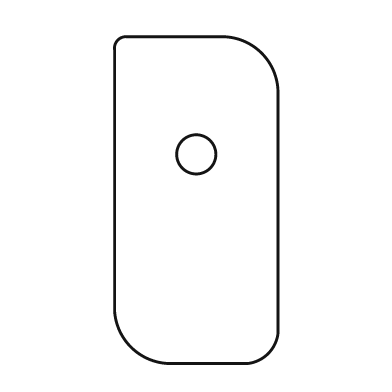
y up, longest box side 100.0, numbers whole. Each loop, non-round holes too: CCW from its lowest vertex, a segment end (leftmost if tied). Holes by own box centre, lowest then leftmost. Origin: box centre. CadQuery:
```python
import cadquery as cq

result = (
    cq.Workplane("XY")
    .moveTo(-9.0, -50.0)
    .lineTo(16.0, -50.0)
    .threePointArc((22.0, -47.0), (25.0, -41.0))
    .lineTo(25.0, 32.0)
    .threePointArc((20.0, 45.0), (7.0, 50.0))
    .lineTo(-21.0, 50.0)
    .threePointArc((-24.0, 49.0), (-25.0, 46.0))
    .lineTo(-25.0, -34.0)
    .threePointArc((-20.0, -45.0), (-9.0, -50.0))
    .close()
    .moveTo(0.0, 14.0)
    .circle(6.0)
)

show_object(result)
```